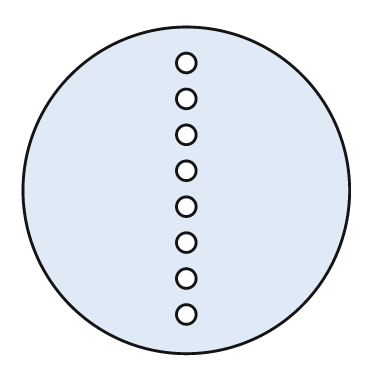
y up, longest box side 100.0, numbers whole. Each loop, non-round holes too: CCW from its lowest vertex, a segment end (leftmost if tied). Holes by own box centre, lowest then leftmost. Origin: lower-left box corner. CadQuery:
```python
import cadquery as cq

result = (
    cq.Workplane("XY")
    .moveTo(50.0, 50.0)
    .circle(50.0)
    .moveTo(50.0, 12.0)
    .circle(3.0)
    .moveTo(50.0, 23.0)
    .circle(3.0)
    .moveTo(50.0, 34.0)
    .circle(3.0)
    .moveTo(50.0, 45.0)
    .circle(3.0)
    .moveTo(50.0, 56.0)
    .circle(3.0)
    .moveTo(50.0, 67.0)
    .circle(3.0)
    .moveTo(50.0, 78.0)
    .circle(3.0)
    .moveTo(50.0, 89.0)
    .circle(3.0)
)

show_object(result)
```